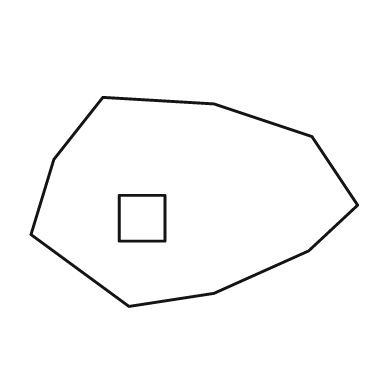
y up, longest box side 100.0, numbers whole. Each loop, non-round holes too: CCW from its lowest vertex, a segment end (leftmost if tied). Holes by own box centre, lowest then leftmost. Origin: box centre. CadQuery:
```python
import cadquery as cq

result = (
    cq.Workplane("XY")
    .moveTo(-20.0, -32.0)
    .lineTo(6.0, -28.0)
    .lineTo(35.0, -15.0)
    .lineTo(50.0, -1.0)
    .lineTo(36.0, 20.0)
    .lineTo(6.0, 30.0)
    .lineTo(-28.0, 32.0)
    .lineTo(-43.0, 13.0)
    .lineTo(-50.0, -10.0)
    .close()
    .moveTo(-23.0, -12.0)
    .lineTo(-9.0, -12.0)
    .lineTo(-9.0, 2.0)
    .lineTo(-23.0, 2.0)
    .close()
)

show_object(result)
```